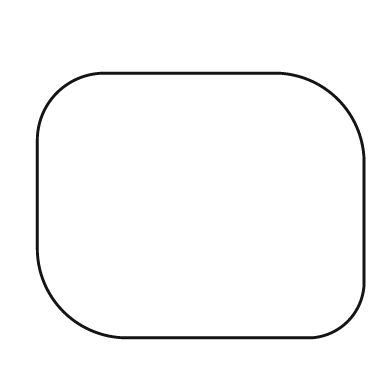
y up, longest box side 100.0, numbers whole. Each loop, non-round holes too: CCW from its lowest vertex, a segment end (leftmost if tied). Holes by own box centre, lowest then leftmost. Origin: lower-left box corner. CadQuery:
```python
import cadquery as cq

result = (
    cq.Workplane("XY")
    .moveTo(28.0, 0.0)
    .lineTo(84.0, 0.0)
    .threePointArc((95.0, 5.0), (100.0, 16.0))
    .lineTo(100.0, 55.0)
    .threePointArc((92.0, 73.0), (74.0, 81.0))
    .lineTo(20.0, 81.0)
    .threePointArc((6.0, 75.0), (0.0, 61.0))
    .lineTo(0.0, 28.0)
    .threePointArc((8.0, 8.0), (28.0, 0.0))
    .close()
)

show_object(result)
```